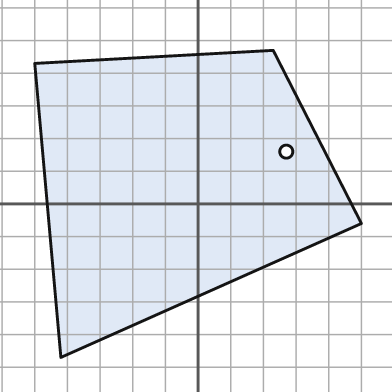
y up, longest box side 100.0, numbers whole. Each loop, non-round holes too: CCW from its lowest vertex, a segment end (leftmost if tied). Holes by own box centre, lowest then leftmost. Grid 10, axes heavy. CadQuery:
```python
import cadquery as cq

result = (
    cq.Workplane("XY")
    .moveTo(-42.0, -47.0)
    .lineTo(50.0, -6.0)
    .lineTo(23.0, 47.0)
    .lineTo(-50.0, 43.0)
    .close()
    .moveTo(27.0, 16.0)
    .circle(2.0)
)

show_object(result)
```